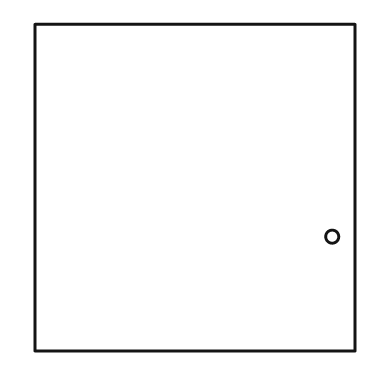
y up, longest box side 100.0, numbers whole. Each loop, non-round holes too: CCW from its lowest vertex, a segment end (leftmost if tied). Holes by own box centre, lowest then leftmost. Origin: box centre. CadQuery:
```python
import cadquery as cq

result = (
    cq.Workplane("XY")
    .moveTo(-49.0, -50.0)
    .lineTo(49.0, -50.0)
    .lineTo(49.0, 50.0)
    .lineTo(-49.0, 50.0)
    .close()
    .moveTo(42.0, -15.0)
    .circle(2.0)
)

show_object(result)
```